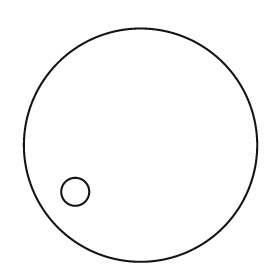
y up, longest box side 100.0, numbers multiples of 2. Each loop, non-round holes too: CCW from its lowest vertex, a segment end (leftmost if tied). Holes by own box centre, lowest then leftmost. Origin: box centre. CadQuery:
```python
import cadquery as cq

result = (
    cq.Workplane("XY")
    .moveTo(0.0, 0.0)
    .circle(50.0)
    .moveTo(-28.0, -20.0)
    .circle(6.0)
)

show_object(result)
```